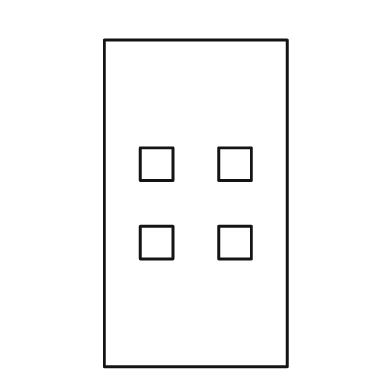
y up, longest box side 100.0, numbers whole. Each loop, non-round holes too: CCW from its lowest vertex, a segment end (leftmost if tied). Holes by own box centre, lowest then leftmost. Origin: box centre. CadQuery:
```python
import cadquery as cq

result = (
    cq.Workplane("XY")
    .moveTo(-28.0, -50.0)
    .lineTo(28.0, -50.0)
    .lineTo(28.0, 50.0)
    .lineTo(-28.0, 50.0)
    .close()
    .moveTo(-17.0, -17.0)
    .lineTo(-7.0, -17.0)
    .lineTo(-7.0, -7.0)
    .lineTo(-17.0, -7.0)
    .close()
    .moveTo(7.0, -17.0)
    .lineTo(17.0, -17.0)
    .lineTo(17.0, -7.0)
    .lineTo(7.0, -7.0)
    .close()
    .moveTo(-17.0, 7.0)
    .lineTo(-7.0, 7.0)
    .lineTo(-7.0, 17.0)
    .lineTo(-17.0, 17.0)
    .close()
    .moveTo(7.0, 7.0)
    .lineTo(17.0, 7.0)
    .lineTo(17.0, 17.0)
    .lineTo(7.0, 17.0)
    .close()
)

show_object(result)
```